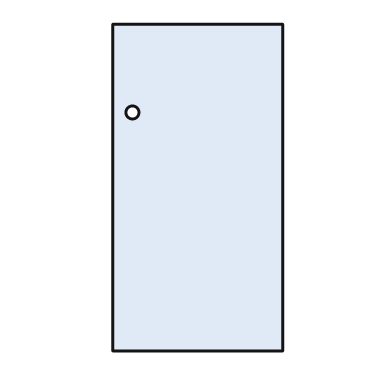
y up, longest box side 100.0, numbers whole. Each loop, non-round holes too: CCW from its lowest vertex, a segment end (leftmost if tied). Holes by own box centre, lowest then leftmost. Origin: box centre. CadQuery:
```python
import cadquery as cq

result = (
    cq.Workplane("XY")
    .moveTo(-26.0, -50.0)
    .lineTo(26.0, -50.0)
    .lineTo(26.0, 50.0)
    .lineTo(-26.0, 50.0)
    .close()
    .moveTo(-20.0, 23.0)
    .circle(2.0)
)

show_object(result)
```